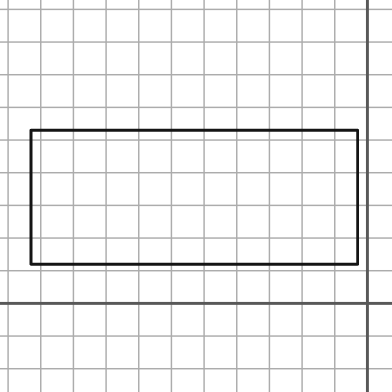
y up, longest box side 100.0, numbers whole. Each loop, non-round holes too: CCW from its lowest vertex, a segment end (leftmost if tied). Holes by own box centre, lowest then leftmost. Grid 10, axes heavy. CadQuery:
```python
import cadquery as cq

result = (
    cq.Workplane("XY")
    .moveTo(-103.0, 12.0)
    .lineTo(-3.0, 12.0)
    .lineTo(-3.0, 53.0)
    .lineTo(-103.0, 53.0)
    .close()
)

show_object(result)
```